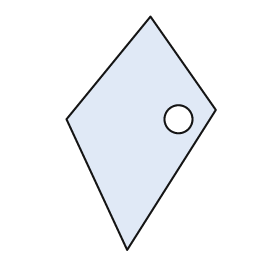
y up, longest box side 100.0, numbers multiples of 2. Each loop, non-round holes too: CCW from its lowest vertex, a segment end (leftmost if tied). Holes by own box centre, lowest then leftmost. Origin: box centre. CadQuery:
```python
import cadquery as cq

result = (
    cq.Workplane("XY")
    .moveTo(-6.0, -50.0)
    .lineTo(32.0, 10.0)
    .lineTo(4.0, 50.0)
    .lineTo(-32.0, 6.0)
    .close()
    .moveTo(16.0, 6.0)
    .circle(6.0)
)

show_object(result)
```